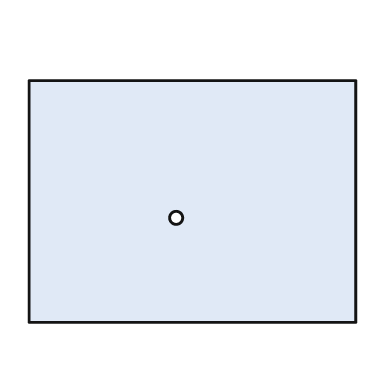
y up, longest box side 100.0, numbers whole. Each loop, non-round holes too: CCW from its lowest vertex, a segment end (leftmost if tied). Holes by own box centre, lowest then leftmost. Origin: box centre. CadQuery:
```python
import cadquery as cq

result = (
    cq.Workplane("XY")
    .moveTo(-50.0, -37.0)
    .lineTo(50.0, -37.0)
    .lineTo(50.0, 37.0)
    .lineTo(-50.0, 37.0)
    .close()
    .moveTo(-5.0, -5.0)
    .circle(2.0)
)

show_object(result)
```